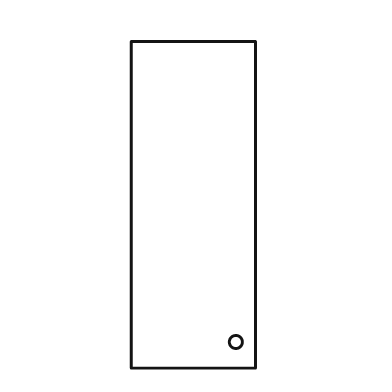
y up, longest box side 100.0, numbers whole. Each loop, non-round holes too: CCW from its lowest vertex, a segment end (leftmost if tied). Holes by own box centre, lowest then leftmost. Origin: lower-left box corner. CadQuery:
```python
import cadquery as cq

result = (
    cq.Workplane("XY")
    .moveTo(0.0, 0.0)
    .lineTo(38.0, 0.0)
    .lineTo(38.0, 100.0)
    .lineTo(0.0, 100.0)
    .close()
    .moveTo(32.0, 8.0)
    .circle(2.0)
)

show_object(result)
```